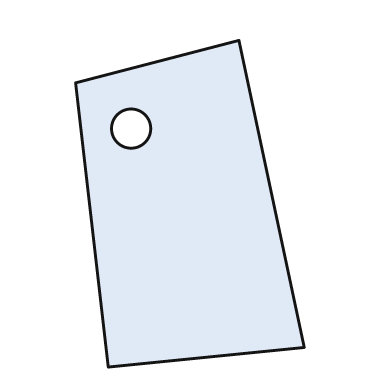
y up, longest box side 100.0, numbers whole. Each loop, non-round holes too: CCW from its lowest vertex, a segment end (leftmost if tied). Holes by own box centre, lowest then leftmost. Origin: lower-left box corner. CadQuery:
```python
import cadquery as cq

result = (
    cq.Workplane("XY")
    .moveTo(10.0, 0.0)
    .lineTo(70.0, 6.0)
    .lineTo(50.0, 100.0)
    .lineTo(0.0, 87.0)
    .close()
    .moveTo(17.0, 73.0)
    .circle(6.0)
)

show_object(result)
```